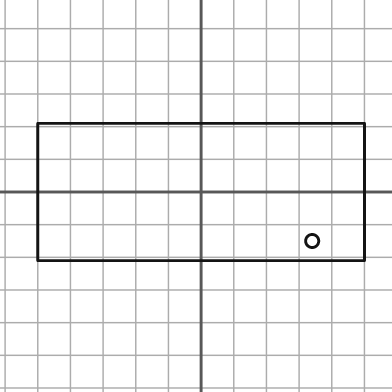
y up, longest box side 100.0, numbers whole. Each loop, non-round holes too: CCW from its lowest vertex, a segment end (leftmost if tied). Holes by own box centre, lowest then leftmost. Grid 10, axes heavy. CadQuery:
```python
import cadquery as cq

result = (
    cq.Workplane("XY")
    .moveTo(-50.0, -21.0)
    .lineTo(50.0, -21.0)
    .lineTo(50.0, 21.0)
    .lineTo(-50.0, 21.0)
    .close()
    .moveTo(34.0, -15.0)
    .circle(2.0)
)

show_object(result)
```